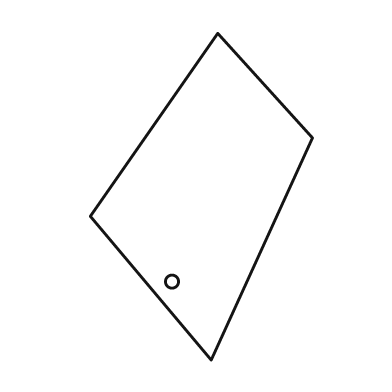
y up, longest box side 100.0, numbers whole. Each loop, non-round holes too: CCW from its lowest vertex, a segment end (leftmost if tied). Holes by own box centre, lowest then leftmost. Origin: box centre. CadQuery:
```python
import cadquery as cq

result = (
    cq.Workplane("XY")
    .moveTo(3.0, -50.0)
    .lineTo(34.0, 18.0)
    .lineTo(5.0, 50.0)
    .lineTo(-34.0, -6.0)
    .close()
    .moveTo(-9.0, -26.0)
    .circle(2.0)
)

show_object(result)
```